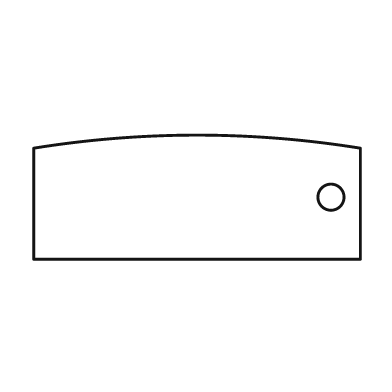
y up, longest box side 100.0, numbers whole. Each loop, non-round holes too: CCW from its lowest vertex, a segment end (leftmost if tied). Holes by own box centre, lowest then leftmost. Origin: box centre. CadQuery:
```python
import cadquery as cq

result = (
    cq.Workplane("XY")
    .moveTo(-50.0, -19.0)
    .lineTo(50.0, -19.0)
    .lineTo(50.0, 15.0)
    .threePointArc((0.0, 19.0), (-50.0, 15.0))
    .close()
    .moveTo(41.0, 0.0)
    .circle(4.0)
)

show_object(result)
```